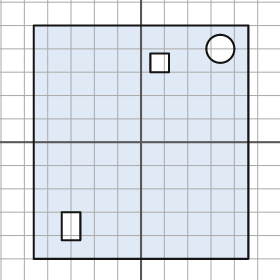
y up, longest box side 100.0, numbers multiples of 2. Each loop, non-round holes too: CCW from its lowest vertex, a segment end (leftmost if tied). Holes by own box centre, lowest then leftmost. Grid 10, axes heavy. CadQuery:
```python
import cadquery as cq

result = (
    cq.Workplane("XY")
    .moveTo(-46.0, -50.0)
    .lineTo(46.0, -50.0)
    .lineTo(46.0, 50.0)
    .lineTo(-46.0, 50.0)
    .close()
    .moveTo(-34.0, -42.0)
    .lineTo(-26.0, -42.0)
    .lineTo(-26.0, -30.0)
    .lineTo(-34.0, -30.0)
    .close()
    .moveTo(4.0, 30.0)
    .lineTo(12.0, 30.0)
    .lineTo(12.0, 38.0)
    .lineTo(4.0, 38.0)
    .close()
    .moveTo(34.0, 40.0)
    .circle(6.0)
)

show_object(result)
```